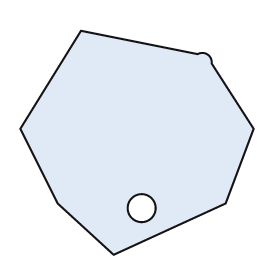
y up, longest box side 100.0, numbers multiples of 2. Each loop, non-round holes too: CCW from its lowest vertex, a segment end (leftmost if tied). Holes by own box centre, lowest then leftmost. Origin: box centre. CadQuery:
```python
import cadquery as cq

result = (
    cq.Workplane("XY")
    .moveTo(-10.0, -48.0)
    .lineTo(38.0, -26.0)
    .lineTo(50.0, 6.0)
    .lineTo(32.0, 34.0)
    .threePointArc((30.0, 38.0), (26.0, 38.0))
    .lineTo(-24.0, 48.0)
    .lineTo(-50.0, 6.0)
    .lineTo(-34.0, -26.0)
    .close()
    .moveTo(2.0, -28.0)
    .circle(6.0)
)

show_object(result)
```